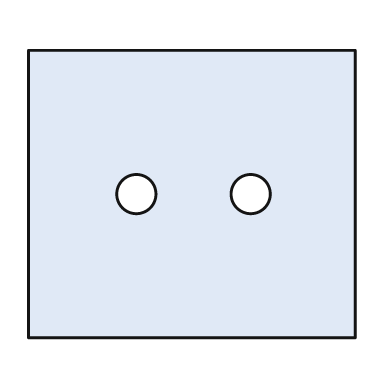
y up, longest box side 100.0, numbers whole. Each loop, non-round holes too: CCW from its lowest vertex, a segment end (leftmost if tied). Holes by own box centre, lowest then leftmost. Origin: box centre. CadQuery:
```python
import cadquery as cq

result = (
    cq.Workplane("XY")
    .moveTo(-50.0, -44.0)
    .lineTo(50.0, -44.0)
    .lineTo(50.0, 44.0)
    .lineTo(-50.0, 44.0)
    .close()
    .moveTo(-17.0, 0.0)
    .circle(6.0)
    .moveTo(18.0, 0.0)
    .circle(6.0)
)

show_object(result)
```